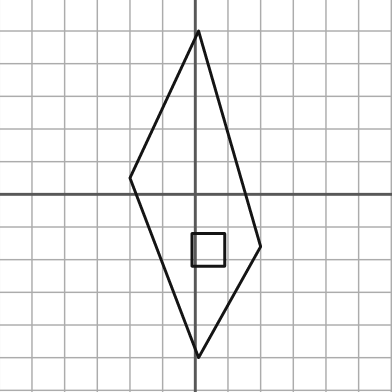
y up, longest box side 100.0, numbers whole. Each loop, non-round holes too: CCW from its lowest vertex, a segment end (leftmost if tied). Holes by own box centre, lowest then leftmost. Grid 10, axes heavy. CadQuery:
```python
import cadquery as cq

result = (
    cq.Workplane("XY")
    .moveTo(1.0, -50.0)
    .lineTo(20.0, -16.0)
    .lineTo(1.0, 50.0)
    .lineTo(-20.0, 5.0)
    .close()
    .moveTo(-1.0, -22.0)
    .lineTo(9.0, -22.0)
    .lineTo(9.0, -12.0)
    .lineTo(-1.0, -12.0)
    .close()
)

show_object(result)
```